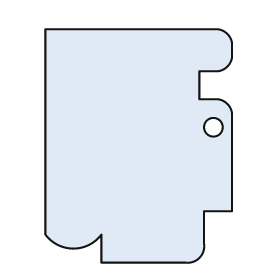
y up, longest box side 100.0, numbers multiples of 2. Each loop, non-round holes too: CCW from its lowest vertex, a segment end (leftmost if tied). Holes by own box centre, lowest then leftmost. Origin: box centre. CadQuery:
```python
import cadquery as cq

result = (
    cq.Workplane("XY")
    .moveTo(-16.0, -50.0)
    .lineTo(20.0, -50.0)
    .threePointArc((26.0, -48.0), (28.0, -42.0))
    .lineTo(28.0, -28.0)
    .lineTo(40.0, -28.0)
    .lineTo(40.0, 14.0)
    .threePointArc((38.0, 18.0), (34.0, 20.0))
    .lineTo(26.0, 20.0)
    .lineTo(26.0, 32.0)
    .lineTo(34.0, 32.0)
    .threePointArc((38.0, 34.0), (40.0, 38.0))
    .lineTo(40.0, 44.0)
    .threePointArc((38.0, 48.0), (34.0, 50.0))
    .lineTo(-40.0, 50.0)
    .lineTo(-40.0, -38.0)
    .threePointArc((-28.0, -44.0), (-16.0, -38.0))
    .close()
    .moveTo(32.0, 8.0)
    .circle(4.0)
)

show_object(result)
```